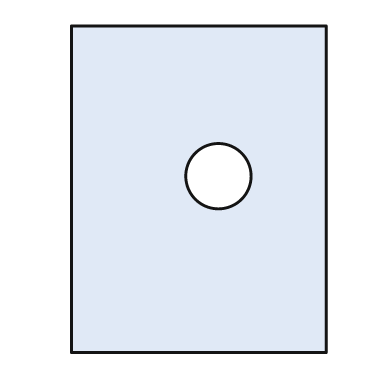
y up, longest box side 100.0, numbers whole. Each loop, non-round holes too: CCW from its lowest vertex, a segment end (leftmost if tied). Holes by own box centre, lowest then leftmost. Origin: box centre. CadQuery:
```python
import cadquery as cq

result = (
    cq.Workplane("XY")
    .moveTo(-39.0, -50.0)
    .lineTo(39.0, -50.0)
    .lineTo(39.0, 50.0)
    .lineTo(-39.0, 50.0)
    .close()
    .moveTo(6.0, 4.0)
    .circle(10.0)
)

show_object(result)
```